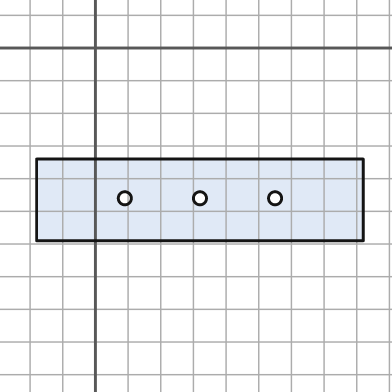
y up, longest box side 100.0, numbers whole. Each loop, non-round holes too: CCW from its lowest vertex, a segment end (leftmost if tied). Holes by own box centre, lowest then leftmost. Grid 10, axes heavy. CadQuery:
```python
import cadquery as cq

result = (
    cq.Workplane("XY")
    .moveTo(-18.0, -59.0)
    .lineTo(82.0, -59.0)
    .lineTo(82.0, -34.0)
    .lineTo(-18.0, -34.0)
    .close()
    .moveTo(9.0, -46.0)
    .circle(2.0)
    .moveTo(32.0, -46.0)
    .circle(2.0)
    .moveTo(55.0, -46.0)
    .circle(2.0)
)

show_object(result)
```